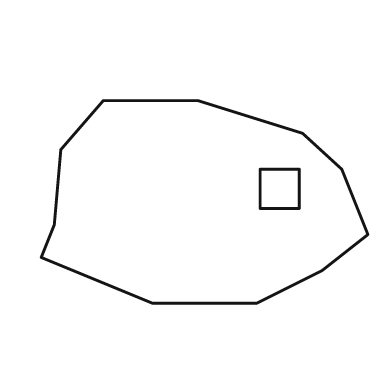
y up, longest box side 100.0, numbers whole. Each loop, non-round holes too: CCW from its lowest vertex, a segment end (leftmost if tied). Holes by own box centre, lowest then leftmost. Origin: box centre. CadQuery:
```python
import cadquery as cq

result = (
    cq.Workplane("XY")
    .moveTo(-16.0, -31.0)
    .lineTo(16.0, -31.0)
    .lineTo(36.0, -21.0)
    .lineTo(50.0, -10.0)
    .lineTo(42.0, 10.0)
    .lineTo(30.0, 21.0)
    .lineTo(-2.0, 31.0)
    .lineTo(-31.0, 31.0)
    .lineTo(-44.0, 16.0)
    .lineTo(-46.0, -7.0)
    .lineTo(-50.0, -17.0)
    .close()
    .moveTo(17.0, -2.0)
    .lineTo(29.0, -2.0)
    .lineTo(29.0, 10.0)
    .lineTo(17.0, 10.0)
    .close()
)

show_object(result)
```